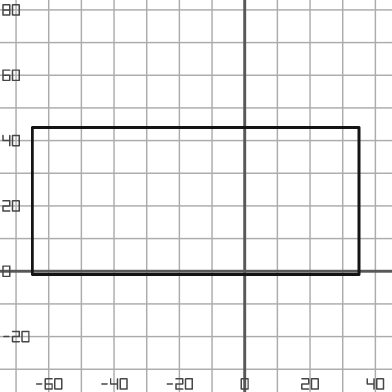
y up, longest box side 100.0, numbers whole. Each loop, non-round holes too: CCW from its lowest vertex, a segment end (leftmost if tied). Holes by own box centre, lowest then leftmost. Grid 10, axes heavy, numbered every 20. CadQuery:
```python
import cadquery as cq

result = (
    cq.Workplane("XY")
    .moveTo(-65.0, -1.0)
    .lineTo(35.0, -1.0)
    .lineTo(35.0, 44.0)
    .lineTo(-65.0, 44.0)
    .close()
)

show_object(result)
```